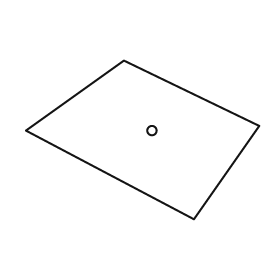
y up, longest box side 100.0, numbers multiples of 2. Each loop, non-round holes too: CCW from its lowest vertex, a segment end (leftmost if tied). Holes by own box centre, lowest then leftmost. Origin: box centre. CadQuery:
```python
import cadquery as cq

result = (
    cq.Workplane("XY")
    .moveTo(22.0, -34.0)
    .lineTo(50.0, 6.0)
    .lineTo(-8.0, 34.0)
    .lineTo(-50.0, 4.0)
    .close()
    .moveTo(4.0, 4.0)
    .circle(2.0)
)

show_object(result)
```